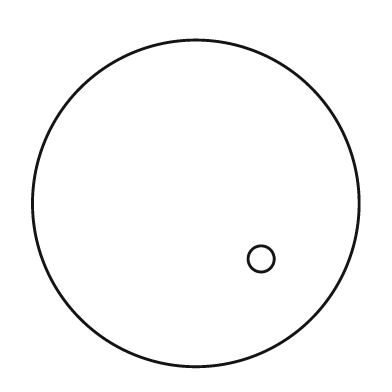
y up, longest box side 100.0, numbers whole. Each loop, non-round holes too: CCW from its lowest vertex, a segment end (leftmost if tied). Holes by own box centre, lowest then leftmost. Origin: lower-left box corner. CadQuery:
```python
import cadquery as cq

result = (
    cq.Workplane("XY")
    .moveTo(50.0, 50.0)
    .circle(50.0)
    .moveTo(70.0, 33.0)
    .circle(4.0)
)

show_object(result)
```